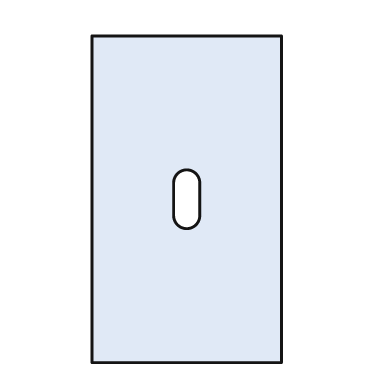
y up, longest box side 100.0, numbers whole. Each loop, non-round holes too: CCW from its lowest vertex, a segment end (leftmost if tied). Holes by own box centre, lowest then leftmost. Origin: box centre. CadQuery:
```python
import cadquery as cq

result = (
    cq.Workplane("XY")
    .moveTo(-29.0, -50.0)
    .lineTo(29.0, -50.0)
    .lineTo(29.0, 50.0)
    .lineTo(-29.0, 50.0)
    .close()
    .moveTo(-4.0, -5.0)
    .threePointArc((0.0, -9.0), (4.0, -5.0))
    .lineTo(4.0, 5.0)
    .threePointArc((0.0, 9.0), (-4.0, 5.0))
    .close()
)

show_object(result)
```